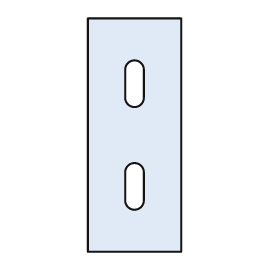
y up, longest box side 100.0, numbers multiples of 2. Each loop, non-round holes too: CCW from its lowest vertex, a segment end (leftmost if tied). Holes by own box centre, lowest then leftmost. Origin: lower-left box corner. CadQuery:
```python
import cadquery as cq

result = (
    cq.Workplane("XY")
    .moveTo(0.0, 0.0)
    .lineTo(40.0, 0.0)
    .lineTo(40.0, 100.0)
    .lineTo(0.0, 100.0)
    .close()
    .moveTo(16.0, 22.0)
    .threePointArc((20.0, 18.0), (24.0, 22.0))
    .lineTo(24.0, 34.0)
    .threePointArc((20.0, 38.0), (16.0, 34.0))
    .close()
    .moveTo(16.0, 66.0)
    .threePointArc((20.0, 62.0), (24.0, 66.0))
    .lineTo(24.0, 78.0)
    .threePointArc((20.0, 82.0), (16.0, 78.0))
    .close()
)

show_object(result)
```